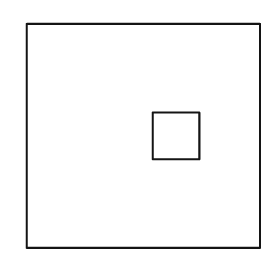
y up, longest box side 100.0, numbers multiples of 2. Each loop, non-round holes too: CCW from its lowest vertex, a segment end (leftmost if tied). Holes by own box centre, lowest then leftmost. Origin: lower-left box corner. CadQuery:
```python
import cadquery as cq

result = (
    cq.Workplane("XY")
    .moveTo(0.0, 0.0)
    .lineTo(100.0, 0.0)
    .lineTo(100.0, 96.0)
    .lineTo(0.0, 96.0)
    .close()
    .moveTo(54.0, 38.0)
    .lineTo(74.0, 38.0)
    .lineTo(74.0, 58.0)
    .lineTo(54.0, 58.0)
    .close()
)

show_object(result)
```